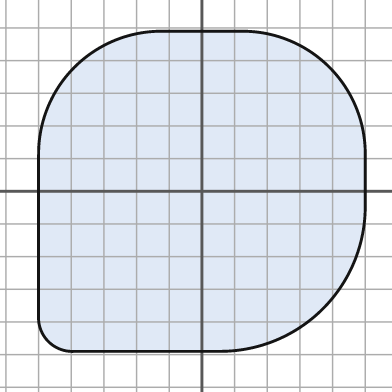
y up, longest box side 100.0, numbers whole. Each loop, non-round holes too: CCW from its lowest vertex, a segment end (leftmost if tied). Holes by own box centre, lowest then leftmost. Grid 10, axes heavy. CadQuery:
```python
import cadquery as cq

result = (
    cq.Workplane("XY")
    .moveTo(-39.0, -49.0)
    .lineTo(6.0, -49.0)
    .threePointArc((37.0, -36.0), (50.0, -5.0))
    .lineTo(50.0, 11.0)
    .threePointArc((39.0, 38.0), (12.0, 49.0))
    .lineTo(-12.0, 49.0)
    .threePointArc((-39.0, 38.0), (-50.0, 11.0))
    .lineTo(-50.0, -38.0)
    .threePointArc((-47.0, -46.0), (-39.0, -49.0))
    .close()
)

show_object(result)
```